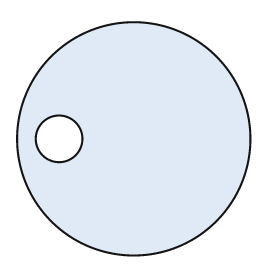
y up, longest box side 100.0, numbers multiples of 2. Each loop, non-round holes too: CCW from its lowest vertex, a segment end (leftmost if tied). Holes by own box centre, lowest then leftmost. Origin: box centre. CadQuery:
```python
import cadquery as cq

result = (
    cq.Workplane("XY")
    .moveTo(0.0, 0.0)
    .circle(50.0)
    .moveTo(-32.0, 0.0)
    .circle(10.0)
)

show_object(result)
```